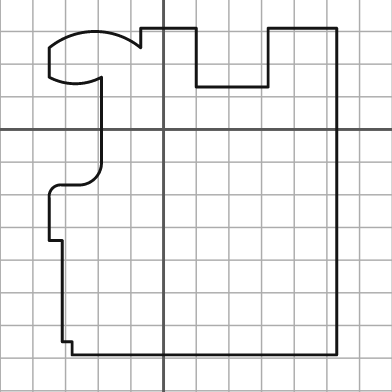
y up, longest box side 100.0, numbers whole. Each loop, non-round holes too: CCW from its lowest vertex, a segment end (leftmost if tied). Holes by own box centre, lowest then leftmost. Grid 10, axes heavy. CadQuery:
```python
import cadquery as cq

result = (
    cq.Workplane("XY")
    .moveTo(-28.0, -69.0)
    .lineTo(53.0, -69.0)
    .lineTo(53.0, 31.0)
    .lineTo(32.0, 31.0)
    .lineTo(32.0, 13.0)
    .lineTo(10.0, 13.0)
    .lineTo(10.0, 31.0)
    .lineTo(-7.0, 31.0)
    .lineTo(-7.0, 25.0)
    .threePointArc((-21.0, 30.0), (-35.0, 25.0))
    .lineTo(-35.0, 16.0)
    .threePointArc((-27.0, 14.0), (-19.0, 16.0))
    .lineTo(-19.0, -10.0)
    .threePointArc((-21.0, -15.0), (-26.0, -17.0))
    .lineTo(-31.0, -17.0)
    .threePointArc((-34.0, -18.0), (-35.0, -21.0))
    .lineTo(-35.0, -34.0)
    .lineTo(-31.0, -34.0)
    .lineTo(-31.0, -65.0)
    .lineTo(-28.0, -65.0)
    .close()
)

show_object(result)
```